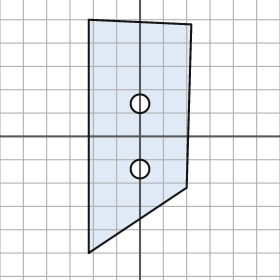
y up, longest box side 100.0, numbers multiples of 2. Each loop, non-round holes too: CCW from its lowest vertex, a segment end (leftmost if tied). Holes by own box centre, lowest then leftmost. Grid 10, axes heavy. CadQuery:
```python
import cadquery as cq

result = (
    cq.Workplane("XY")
    .moveTo(-22.0, -50.0)
    .lineTo(20.0, -22.0)
    .lineTo(22.0, 48.0)
    .lineTo(-22.0, 50.0)
    .close()
    .moveTo(0.0, -14.0)
    .circle(4.0)
    .moveTo(0.0, 14.0)
    .circle(4.0)
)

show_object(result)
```